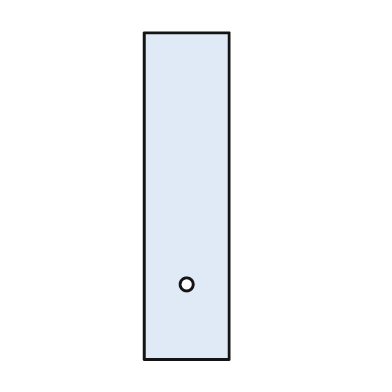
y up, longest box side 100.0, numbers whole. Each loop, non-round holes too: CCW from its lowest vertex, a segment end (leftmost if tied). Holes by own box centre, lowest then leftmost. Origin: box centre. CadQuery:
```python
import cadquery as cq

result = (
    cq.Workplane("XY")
    .moveTo(-13.0, -50.0)
    .lineTo(13.0, -50.0)
    .lineTo(13.0, 50.0)
    .lineTo(-13.0, 50.0)
    .close()
    .moveTo(0.0, -27.0)
    .circle(2.0)
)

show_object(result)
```